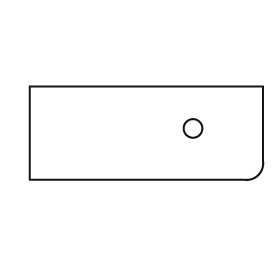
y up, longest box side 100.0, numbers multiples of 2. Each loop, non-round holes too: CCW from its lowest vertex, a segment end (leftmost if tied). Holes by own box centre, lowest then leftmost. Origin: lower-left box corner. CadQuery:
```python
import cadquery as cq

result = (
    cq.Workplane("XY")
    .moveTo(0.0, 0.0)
    .lineTo(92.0, 0.0)
    .threePointArc((98.0, 2.0), (100.0, 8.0))
    .lineTo(100.0, 40.0)
    .lineTo(0.0, 40.0)
    .close()
    .moveTo(70.0, 22.0)
    .circle(4.0)
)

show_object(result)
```